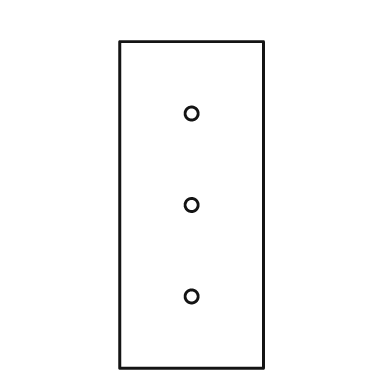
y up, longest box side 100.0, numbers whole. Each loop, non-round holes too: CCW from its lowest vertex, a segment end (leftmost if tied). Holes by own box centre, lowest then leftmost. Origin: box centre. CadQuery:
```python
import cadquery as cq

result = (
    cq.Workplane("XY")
    .moveTo(-22.0, -50.0)
    .lineTo(22.0, -50.0)
    .lineTo(22.0, 50.0)
    .lineTo(-22.0, 50.0)
    .close()
    .moveTo(0.0, -28.0)
    .circle(2.0)
    .moveTo(0.0, 0.0)
    .circle(2.0)
    .moveTo(0.0, 28.0)
    .circle(2.0)
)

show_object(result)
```